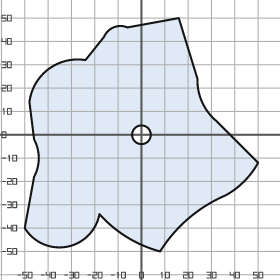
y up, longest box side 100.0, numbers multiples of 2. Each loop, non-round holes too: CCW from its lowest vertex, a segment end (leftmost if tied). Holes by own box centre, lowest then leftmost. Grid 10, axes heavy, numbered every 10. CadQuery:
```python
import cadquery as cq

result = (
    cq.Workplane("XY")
    .moveTo(8.0, -50.0)
    .threePointArc((20.0, -36.0), (36.0, -26.0))
    .threePointArc((44.0, -20.0), (50.0, -12.0))
    .lineTo(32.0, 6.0)
    .threePointArc((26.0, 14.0), (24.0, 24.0))
    .lineTo(16.0, 50.0)
    .lineTo(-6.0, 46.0)
    .threePointArc((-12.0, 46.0), (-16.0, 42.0))
    .lineTo(-24.0, 32.0)
    .threePointArc((-40.0, 28.0), (-48.0, 14.0))
    .lineTo(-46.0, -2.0)
    .threePointArc((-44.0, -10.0), (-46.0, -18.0))
    .lineTo(-50.0, -40.0)
    .threePointArc((-32.0, -48.0), (-18.0, -34.0))
    .threePointArc((-6.0, -44.0), (8.0, -50.0))
    .close()
    .moveTo(0.0, 0.0)
    .circle(4.0)
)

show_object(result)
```